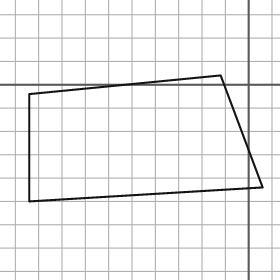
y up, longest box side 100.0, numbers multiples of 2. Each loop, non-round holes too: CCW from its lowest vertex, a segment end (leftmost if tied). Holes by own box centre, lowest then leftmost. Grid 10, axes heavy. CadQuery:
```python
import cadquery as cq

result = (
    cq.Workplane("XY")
    .moveTo(-94.0, -50.0)
    .lineTo(6.0, -44.0)
    .lineTo(-12.0, 4.0)
    .lineTo(-94.0, -4.0)
    .close()
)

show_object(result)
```